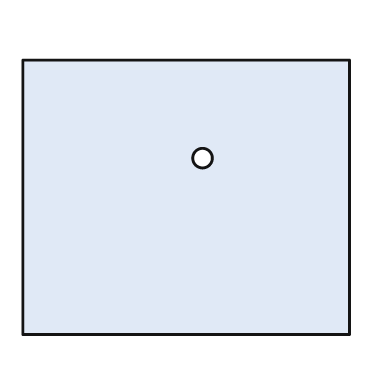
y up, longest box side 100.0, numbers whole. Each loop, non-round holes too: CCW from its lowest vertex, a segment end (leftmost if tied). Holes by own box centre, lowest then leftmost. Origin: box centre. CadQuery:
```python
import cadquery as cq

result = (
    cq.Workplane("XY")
    .moveTo(-50.0, -42.0)
    .lineTo(50.0, -42.0)
    .lineTo(50.0, 42.0)
    .lineTo(-50.0, 42.0)
    .close()
    .moveTo(5.0, 12.0)
    .circle(3.0)
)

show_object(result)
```